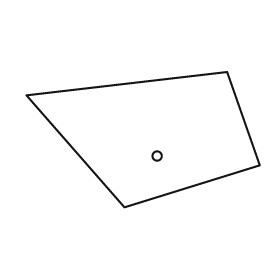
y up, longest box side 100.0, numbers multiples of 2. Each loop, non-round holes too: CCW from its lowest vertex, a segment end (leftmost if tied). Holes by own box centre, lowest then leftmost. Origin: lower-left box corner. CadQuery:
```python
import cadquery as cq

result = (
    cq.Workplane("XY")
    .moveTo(42.0, 0.0)
    .lineTo(100.0, 18.0)
    .lineTo(86.0, 58.0)
    .lineTo(0.0, 48.0)
    .close()
    .moveTo(56.0, 22.0)
    .circle(2.0)
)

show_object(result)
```